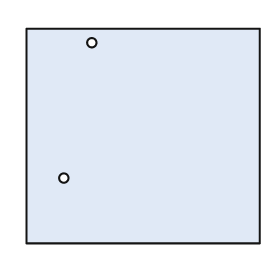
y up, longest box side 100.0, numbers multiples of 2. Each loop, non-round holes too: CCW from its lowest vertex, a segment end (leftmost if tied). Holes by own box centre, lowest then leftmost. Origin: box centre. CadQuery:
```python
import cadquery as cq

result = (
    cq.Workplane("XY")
    .moveTo(-50.0, -46.0)
    .lineTo(50.0, -46.0)
    .lineTo(50.0, 46.0)
    .lineTo(-50.0, 46.0)
    .close()
    .moveTo(-34.0, -18.0)
    .circle(2.0)
    .moveTo(-22.0, 40.0)
    .circle(2.0)
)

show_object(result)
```